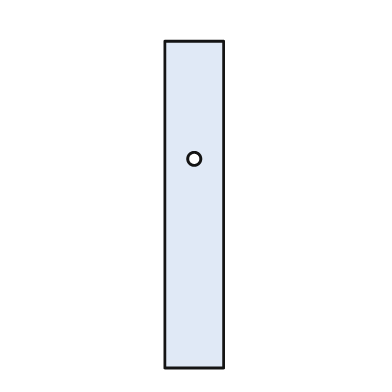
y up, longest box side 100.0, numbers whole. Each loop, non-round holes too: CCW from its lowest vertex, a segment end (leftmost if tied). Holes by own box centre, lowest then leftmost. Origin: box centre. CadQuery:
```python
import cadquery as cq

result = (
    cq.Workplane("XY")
    .moveTo(-9.0, -50.0)
    .lineTo(9.0, -50.0)
    .lineTo(9.0, 50.0)
    .lineTo(-9.0, 50.0)
    .close()
    .moveTo(0.0, 14.0)
    .circle(2.0)
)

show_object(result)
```